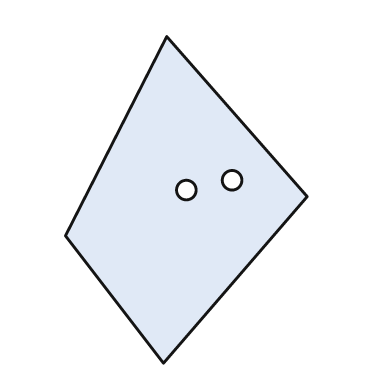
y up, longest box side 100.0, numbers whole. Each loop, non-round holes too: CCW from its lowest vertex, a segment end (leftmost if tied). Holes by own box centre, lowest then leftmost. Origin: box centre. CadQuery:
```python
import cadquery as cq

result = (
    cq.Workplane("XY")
    .moveTo(-7.0, -50.0)
    .lineTo(37.0, 1.0)
    .lineTo(-6.0, 50.0)
    .lineTo(-37.0, -11.0)
    .close()
    .moveTo(0.0, 3.0)
    .circle(3.0)
    .moveTo(14.0, 6.0)
    .circle(3.0)
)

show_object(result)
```